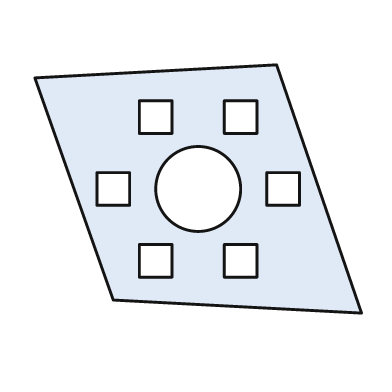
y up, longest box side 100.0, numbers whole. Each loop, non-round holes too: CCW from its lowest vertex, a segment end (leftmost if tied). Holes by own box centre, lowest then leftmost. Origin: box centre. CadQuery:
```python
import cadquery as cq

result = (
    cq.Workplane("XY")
    .moveTo(50.0, -38.0)
    .lineTo(24.0, 38.0)
    .lineTo(-50.0, 34.0)
    .lineTo(-26.0, -34.0)
    .close()
    .moveTo(-18.0, -27.0)
    .lineTo(-8.0, -27.0)
    .lineTo(-8.0, -17.0)
    .lineTo(-18.0, -17.0)
    .close()
    .moveTo(8.0, -27.0)
    .lineTo(18.0, -27.0)
    .lineTo(18.0, -17.0)
    .lineTo(8.0, -17.0)
    .close()
    .moveTo(-31.0, -5.0)
    .lineTo(-21.0, -5.0)
    .lineTo(-21.0, 5.0)
    .lineTo(-31.0, 5.0)
    .close()
    .moveTo(0.0, 0.0)
    .circle(13.0)
    .moveTo(21.0, -5.0)
    .lineTo(31.0, -5.0)
    .lineTo(31.0, 5.0)
    .lineTo(21.0, 5.0)
    .close()
    .moveTo(-18.0, 17.0)
    .lineTo(-8.0, 17.0)
    .lineTo(-8.0, 27.0)
    .lineTo(-18.0, 27.0)
    .close()
    .moveTo(8.0, 17.0)
    .lineTo(18.0, 17.0)
    .lineTo(18.0, 27.0)
    .lineTo(8.0, 27.0)
    .close()
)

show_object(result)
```